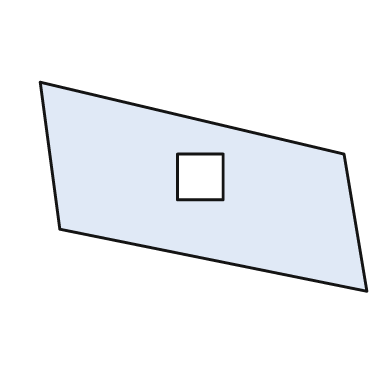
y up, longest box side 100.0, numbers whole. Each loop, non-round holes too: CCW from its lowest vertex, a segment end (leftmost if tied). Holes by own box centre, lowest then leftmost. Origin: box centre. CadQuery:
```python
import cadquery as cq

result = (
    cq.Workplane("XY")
    .moveTo(50.0, -32.0)
    .lineTo(43.0, 10.0)
    .lineTo(-50.0, 32.0)
    .lineTo(-44.0, -13.0)
    .close()
    .moveTo(-8.0, -4.0)
    .lineTo(6.0, -4.0)
    .lineTo(6.0, 10.0)
    .lineTo(-8.0, 10.0)
    .close()
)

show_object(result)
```